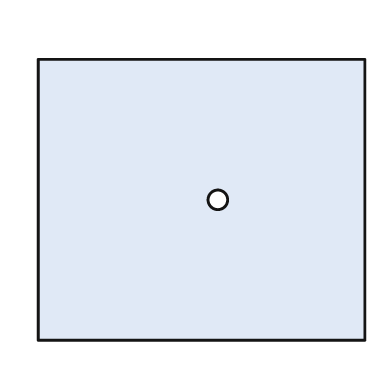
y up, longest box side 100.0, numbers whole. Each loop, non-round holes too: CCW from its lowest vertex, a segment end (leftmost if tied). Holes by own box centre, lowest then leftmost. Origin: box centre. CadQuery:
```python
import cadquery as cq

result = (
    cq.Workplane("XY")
    .moveTo(-50.0, -43.0)
    .lineTo(50.0, -43.0)
    .lineTo(50.0, 43.0)
    .lineTo(-50.0, 43.0)
    .close()
    .moveTo(5.0, 0.0)
    .circle(3.0)
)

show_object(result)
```